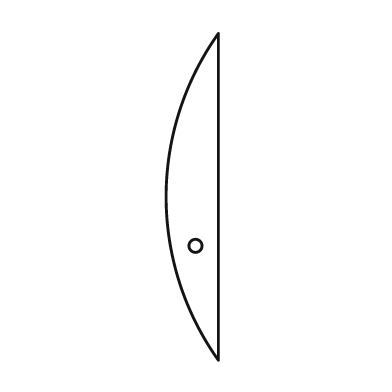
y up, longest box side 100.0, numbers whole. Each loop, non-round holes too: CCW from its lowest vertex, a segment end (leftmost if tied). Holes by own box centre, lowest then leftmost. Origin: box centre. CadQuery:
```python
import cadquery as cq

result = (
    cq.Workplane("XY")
    .moveTo(8.0, -50.0)
    .lineTo(8.0, 50.0)
    .threePointArc((-8.0, 0.0), (8.0, -50.0))
    .close()
    .moveTo(1.0, -15.0)
    .circle(2.0)
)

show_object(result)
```